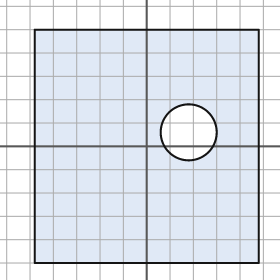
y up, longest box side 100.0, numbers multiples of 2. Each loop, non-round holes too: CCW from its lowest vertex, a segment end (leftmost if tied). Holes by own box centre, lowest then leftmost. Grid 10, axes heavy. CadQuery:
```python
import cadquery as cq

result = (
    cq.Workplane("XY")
    .moveTo(-48.0, -50.0)
    .lineTo(48.0, -50.0)
    .lineTo(48.0, 50.0)
    .lineTo(-48.0, 50.0)
    .close()
    .moveTo(18.0, 6.0)
    .circle(12.0)
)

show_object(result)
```